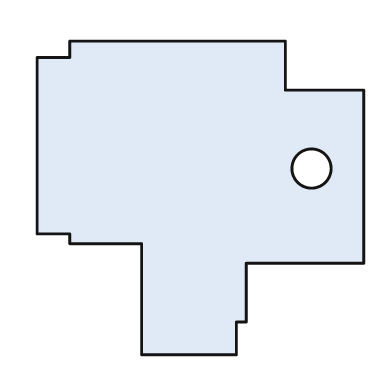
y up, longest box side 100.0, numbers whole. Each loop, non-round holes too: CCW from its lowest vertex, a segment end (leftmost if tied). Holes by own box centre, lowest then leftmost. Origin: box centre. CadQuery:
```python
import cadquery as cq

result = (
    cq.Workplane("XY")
    .moveTo(-18.0, -48.0)
    .lineTo(11.0, -48.0)
    .lineTo(11.0, -38.0)
    .lineTo(14.0, -38.0)
    .lineTo(14.0, -20.0)
    .lineTo(50.0, -20.0)
    .lineTo(50.0, 33.0)
    .lineTo(26.0, 33.0)
    .lineTo(26.0, 48.0)
    .lineTo(-40.0, 48.0)
    .lineTo(-40.0, 43.0)
    .lineTo(-50.0, 43.0)
    .lineTo(-50.0, -11.0)
    .lineTo(-40.0, -11.0)
    .lineTo(-40.0, -14.0)
    .lineTo(-18.0, -14.0)
    .close()
    .moveTo(34.0, 9.0)
    .circle(6.0)
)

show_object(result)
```